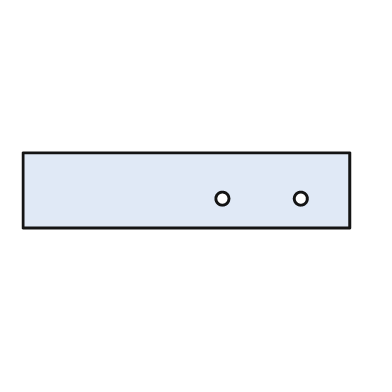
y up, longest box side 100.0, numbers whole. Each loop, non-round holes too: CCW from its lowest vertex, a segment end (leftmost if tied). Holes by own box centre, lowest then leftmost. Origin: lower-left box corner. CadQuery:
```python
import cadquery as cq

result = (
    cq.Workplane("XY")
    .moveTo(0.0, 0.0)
    .lineTo(100.0, 0.0)
    .lineTo(100.0, 23.0)
    .lineTo(0.0, 23.0)
    .close()
    .moveTo(61.0, 9.0)
    .circle(2.0)
    .moveTo(85.0, 9.0)
    .circle(2.0)
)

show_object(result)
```